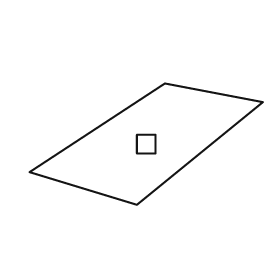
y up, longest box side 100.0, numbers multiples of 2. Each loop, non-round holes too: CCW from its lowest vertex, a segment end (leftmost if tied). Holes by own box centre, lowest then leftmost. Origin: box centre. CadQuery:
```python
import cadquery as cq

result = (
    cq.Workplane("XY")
    .moveTo(-4.0, -26.0)
    .lineTo(50.0, 18.0)
    .lineTo(8.0, 26.0)
    .lineTo(-50.0, -12.0)
    .close()
    .moveTo(-4.0, -4.0)
    .lineTo(4.0, -4.0)
    .lineTo(4.0, 4.0)
    .lineTo(-4.0, 4.0)
    .close()
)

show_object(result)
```